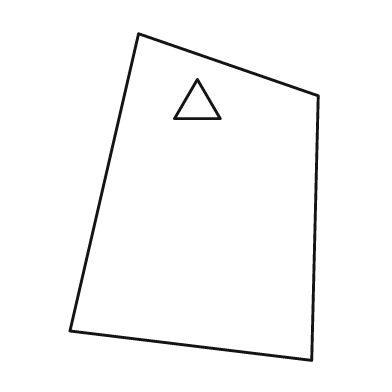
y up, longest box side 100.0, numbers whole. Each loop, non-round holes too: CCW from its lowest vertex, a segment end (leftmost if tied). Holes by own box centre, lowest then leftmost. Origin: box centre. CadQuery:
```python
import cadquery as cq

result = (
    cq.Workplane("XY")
    .moveTo(36.0, -50.0)
    .lineTo(38.0, 31.0)
    .lineTo(-17.0, 50.0)
    .lineTo(-38.0, -41.0)
    .close()
    .moveTo(-6.0, 24.0)
    .lineTo(8.0, 24.0)
    .lineTo(1.0, 36.0)
    .close()
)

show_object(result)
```